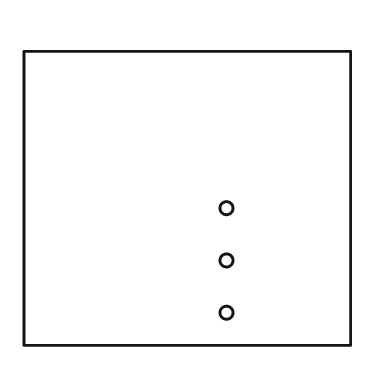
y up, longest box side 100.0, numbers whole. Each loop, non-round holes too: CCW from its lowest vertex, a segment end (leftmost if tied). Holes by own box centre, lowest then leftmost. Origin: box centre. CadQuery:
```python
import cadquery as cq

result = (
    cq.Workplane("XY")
    .moveTo(-50.0, -45.0)
    .lineTo(50.0, -45.0)
    .lineTo(50.0, 45.0)
    .lineTo(-50.0, 45.0)
    .close()
    .moveTo(12.0, -35.0)
    .circle(2.0)
    .moveTo(12.0, -19.0)
    .circle(2.0)
    .moveTo(12.0, -3.0)
    .circle(2.0)
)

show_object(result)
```